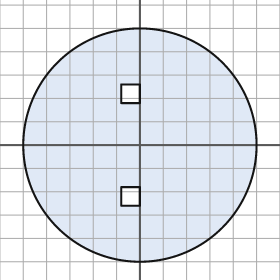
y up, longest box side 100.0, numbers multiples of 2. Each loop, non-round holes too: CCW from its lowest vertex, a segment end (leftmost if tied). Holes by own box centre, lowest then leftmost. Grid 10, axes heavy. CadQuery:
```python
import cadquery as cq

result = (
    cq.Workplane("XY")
    .moveTo(0.0, 0.0)
    .circle(50.0)
    .moveTo(-8.0, -26.0)
    .lineTo(0.0, -26.0)
    .lineTo(0.0, -18.0)
    .lineTo(-8.0, -18.0)
    .close()
    .moveTo(-8.0, 18.0)
    .lineTo(0.0, 18.0)
    .lineTo(0.0, 26.0)
    .lineTo(-8.0, 26.0)
    .close()
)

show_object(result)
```